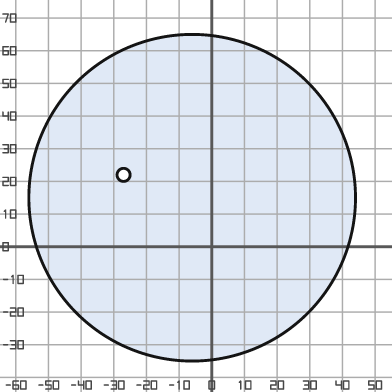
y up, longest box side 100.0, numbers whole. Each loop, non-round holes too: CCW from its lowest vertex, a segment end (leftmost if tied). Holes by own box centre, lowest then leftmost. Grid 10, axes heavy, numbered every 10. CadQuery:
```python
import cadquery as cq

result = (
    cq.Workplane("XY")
    .moveTo(-6.0, 15.0)
    .circle(50.0)
    .moveTo(-27.0, 22.0)
    .circle(2.0)
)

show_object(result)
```